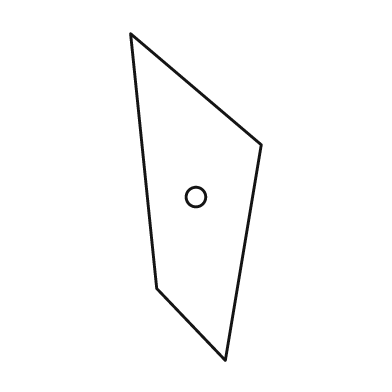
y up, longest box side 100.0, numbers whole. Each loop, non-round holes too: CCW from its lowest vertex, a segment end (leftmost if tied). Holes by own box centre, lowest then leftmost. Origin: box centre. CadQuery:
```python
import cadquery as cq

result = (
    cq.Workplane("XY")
    .moveTo(9.0, -50.0)
    .lineTo(20.0, 16.0)
    .lineTo(-20.0, 50.0)
    .lineTo(-12.0, -28.0)
    .close()
    .moveTo(0.0, 0.0)
    .circle(3.0)
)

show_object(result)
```